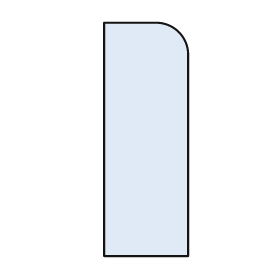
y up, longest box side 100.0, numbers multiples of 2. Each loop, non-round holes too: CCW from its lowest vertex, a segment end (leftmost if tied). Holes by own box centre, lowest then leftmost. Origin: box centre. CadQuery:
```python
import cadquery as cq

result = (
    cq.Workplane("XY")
    .moveTo(-18.0, -50.0)
    .lineTo(18.0, -50.0)
    .lineTo(18.0, 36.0)
    .threePointArc((14.0, 46.0), (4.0, 50.0))
    .lineTo(-18.0, 50.0)
    .close()
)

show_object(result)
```